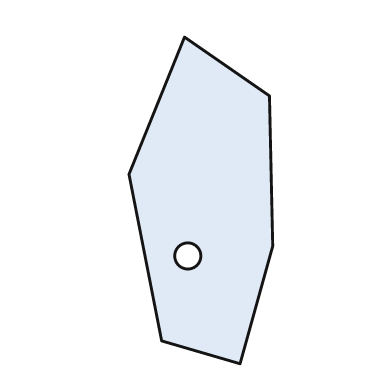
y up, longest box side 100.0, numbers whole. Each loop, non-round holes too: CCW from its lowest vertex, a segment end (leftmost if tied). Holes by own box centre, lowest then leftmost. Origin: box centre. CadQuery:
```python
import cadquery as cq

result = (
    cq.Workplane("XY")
    .moveTo(12.0, -50.0)
    .lineTo(22.0, -14.0)
    .lineTo(21.0, 32.0)
    .lineTo(-5.0, 50.0)
    .lineTo(-22.0, 8.0)
    .lineTo(-12.0, -43.0)
    .close()
    .moveTo(-4.0, -17.0)
    .circle(4.0)
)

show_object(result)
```